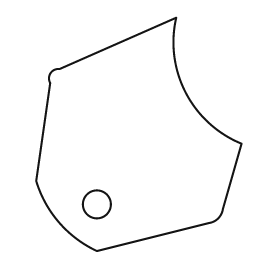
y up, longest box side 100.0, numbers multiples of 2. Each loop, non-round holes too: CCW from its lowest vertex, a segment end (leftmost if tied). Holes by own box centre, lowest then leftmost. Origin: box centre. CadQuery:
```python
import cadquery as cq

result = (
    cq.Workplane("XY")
    .moveTo(-18.0, -50.0)
    .lineTo(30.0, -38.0)
    .threePointArc((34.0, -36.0), (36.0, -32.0))
    .lineTo(44.0, -4.0)
    .threePointArc((20.0, 18.0), (16.0, 50.0))
    .lineTo(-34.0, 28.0)
    .threePointArc((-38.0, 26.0), (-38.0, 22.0))
    .lineTo(-44.0, -20.0)
    .threePointArc((-34.0, -38.0), (-18.0, -50.0))
    .close()
    .moveTo(-18.0, -30.0)
    .circle(6.0)
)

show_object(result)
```